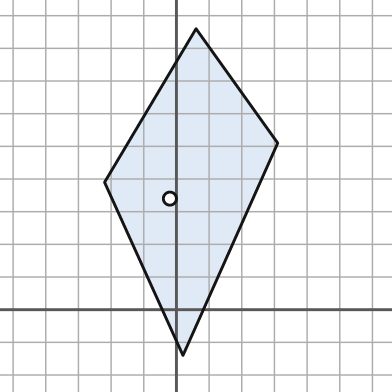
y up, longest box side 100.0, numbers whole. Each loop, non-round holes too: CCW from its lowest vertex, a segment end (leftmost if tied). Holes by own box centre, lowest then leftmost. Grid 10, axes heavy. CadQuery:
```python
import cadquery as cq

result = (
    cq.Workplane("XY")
    .moveTo(2.0, -14.0)
    .lineTo(31.0, 51.0)
    .lineTo(6.0, 86.0)
    .lineTo(-22.0, 39.0)
    .close()
    .moveTo(-2.0, 34.0)
    .circle(2.0)
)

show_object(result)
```